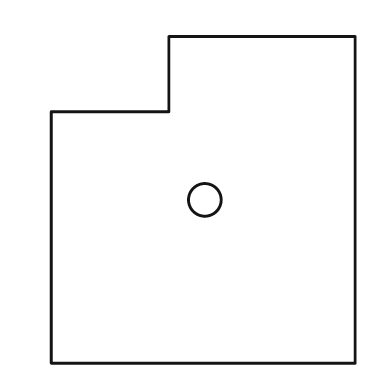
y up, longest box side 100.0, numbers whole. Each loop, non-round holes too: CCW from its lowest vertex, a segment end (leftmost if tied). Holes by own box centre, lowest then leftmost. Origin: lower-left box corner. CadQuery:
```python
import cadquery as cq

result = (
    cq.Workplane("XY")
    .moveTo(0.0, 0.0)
    .lineTo(93.0, 0.0)
    .lineTo(93.0, 100.0)
    .lineTo(36.0, 100.0)
    .lineTo(36.0, 77.0)
    .lineTo(0.0, 77.0)
    .close()
    .moveTo(47.0, 50.0)
    .circle(5.0)
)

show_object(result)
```